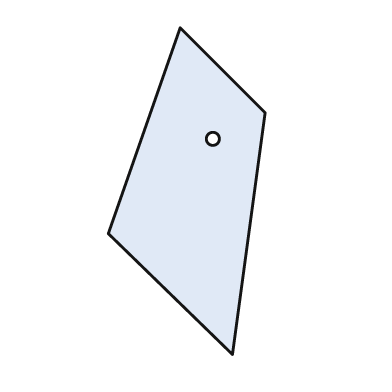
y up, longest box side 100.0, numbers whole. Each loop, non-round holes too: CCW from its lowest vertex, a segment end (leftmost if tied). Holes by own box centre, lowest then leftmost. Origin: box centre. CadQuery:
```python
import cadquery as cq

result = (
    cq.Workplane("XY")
    .moveTo(14.0, -50.0)
    .lineTo(24.0, 24.0)
    .lineTo(-2.0, 50.0)
    .lineTo(-24.0, -13.0)
    .close()
    .moveTo(8.0, 16.0)
    .circle(2.0)
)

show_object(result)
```